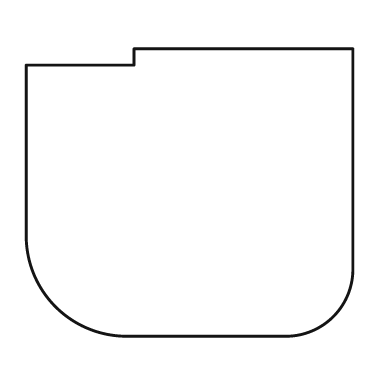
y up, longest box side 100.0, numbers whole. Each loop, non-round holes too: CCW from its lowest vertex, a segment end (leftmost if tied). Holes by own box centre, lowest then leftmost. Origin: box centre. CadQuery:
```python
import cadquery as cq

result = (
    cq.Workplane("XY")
    .moveTo(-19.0, -44.0)
    .lineTo(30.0, -44.0)
    .threePointArc((44.0, -38.0), (50.0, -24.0))
    .lineTo(50.0, 44.0)
    .lineTo(-17.0, 44.0)
    .lineTo(-17.0, 39.0)
    .lineTo(-50.0, 39.0)
    .lineTo(-50.0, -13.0)
    .threePointArc((-41.0, -35.0), (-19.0, -44.0))
    .close()
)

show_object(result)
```